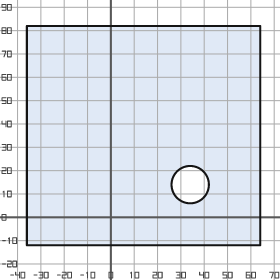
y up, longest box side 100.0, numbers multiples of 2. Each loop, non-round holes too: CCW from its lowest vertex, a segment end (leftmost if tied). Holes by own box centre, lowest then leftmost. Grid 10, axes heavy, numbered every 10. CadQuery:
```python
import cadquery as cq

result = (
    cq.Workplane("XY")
    .moveTo(-36.0, -12.0)
    .lineTo(64.0, -12.0)
    .lineTo(64.0, 82.0)
    .lineTo(-36.0, 82.0)
    .close()
    .moveTo(34.0, 14.0)
    .circle(8.0)
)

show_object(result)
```